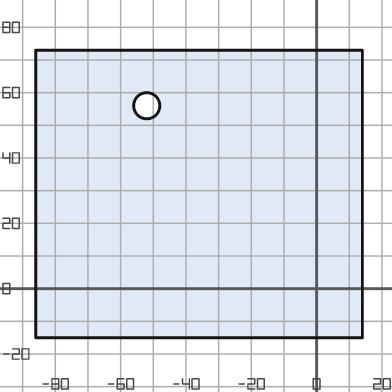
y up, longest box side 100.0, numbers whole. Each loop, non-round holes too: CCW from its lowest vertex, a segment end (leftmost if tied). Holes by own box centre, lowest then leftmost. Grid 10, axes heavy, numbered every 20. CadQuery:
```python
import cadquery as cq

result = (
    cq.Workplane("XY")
    .moveTo(-86.0, -15.0)
    .lineTo(14.0, -15.0)
    .lineTo(14.0, 73.0)
    .lineTo(-86.0, 73.0)
    .close()
    .moveTo(-52.0, 56.0)
    .circle(4.0)
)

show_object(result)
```